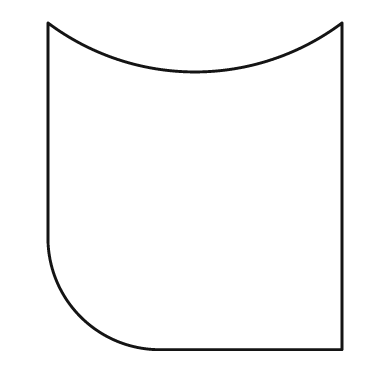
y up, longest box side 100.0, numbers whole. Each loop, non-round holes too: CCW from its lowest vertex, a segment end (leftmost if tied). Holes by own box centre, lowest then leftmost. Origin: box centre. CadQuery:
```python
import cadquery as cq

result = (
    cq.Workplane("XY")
    .moveTo(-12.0, -50.0)
    .lineTo(45.0, -50.0)
    .lineTo(45.0, 50.0)
    .threePointArc((0.0, 35.0), (-45.0, 50.0))
    .lineTo(-45.0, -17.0)
    .threePointArc((-35.0, -40.0), (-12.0, -50.0))
    .close()
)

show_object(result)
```